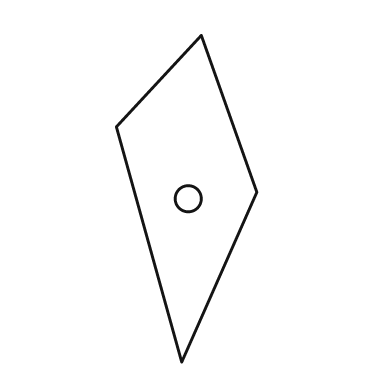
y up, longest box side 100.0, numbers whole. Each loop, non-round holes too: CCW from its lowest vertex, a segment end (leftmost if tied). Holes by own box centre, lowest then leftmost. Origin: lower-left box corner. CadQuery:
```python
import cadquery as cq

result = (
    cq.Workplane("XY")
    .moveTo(20.0, 0.0)
    .lineTo(43.0, 52.0)
    .lineTo(26.0, 100.0)
    .lineTo(0.0, 72.0)
    .close()
    .moveTo(22.0, 50.0)
    .circle(4.0)
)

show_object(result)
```